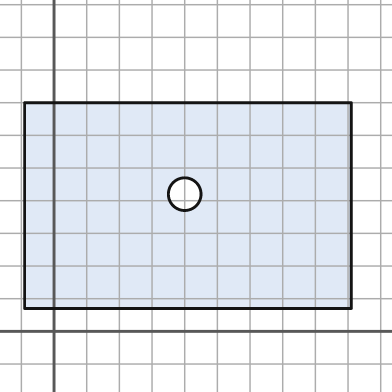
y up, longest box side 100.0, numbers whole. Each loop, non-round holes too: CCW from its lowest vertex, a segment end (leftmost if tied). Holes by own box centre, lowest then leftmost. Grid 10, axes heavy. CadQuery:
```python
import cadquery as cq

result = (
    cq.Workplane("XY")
    .moveTo(-9.0, 7.0)
    .lineTo(91.0, 7.0)
    .lineTo(91.0, 70.0)
    .lineTo(-9.0, 70.0)
    .close()
    .moveTo(40.0, 42.0)
    .circle(5.0)
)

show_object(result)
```